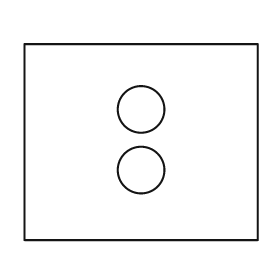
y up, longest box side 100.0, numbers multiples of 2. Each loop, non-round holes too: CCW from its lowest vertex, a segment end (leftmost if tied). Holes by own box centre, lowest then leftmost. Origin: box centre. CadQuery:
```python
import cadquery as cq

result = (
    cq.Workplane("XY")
    .moveTo(-50.0, -42.0)
    .lineTo(50.0, -42.0)
    .lineTo(50.0, 42.0)
    .lineTo(-50.0, 42.0)
    .close()
    .moveTo(0.0, -12.0)
    .circle(10.0)
    .moveTo(0.0, 14.0)
    .circle(10.0)
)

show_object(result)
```